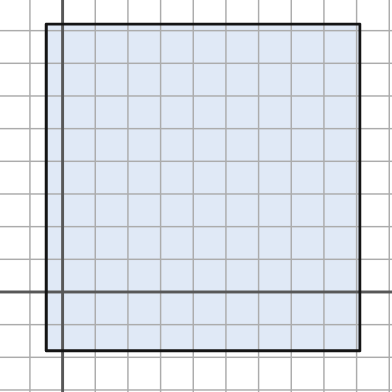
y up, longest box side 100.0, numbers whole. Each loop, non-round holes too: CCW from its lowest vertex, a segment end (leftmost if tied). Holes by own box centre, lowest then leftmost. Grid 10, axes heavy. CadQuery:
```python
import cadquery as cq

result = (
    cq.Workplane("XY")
    .moveTo(-5.0, -18.0)
    .lineTo(91.0, -18.0)
    .lineTo(91.0, 82.0)
    .lineTo(-5.0, 82.0)
    .close()
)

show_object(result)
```